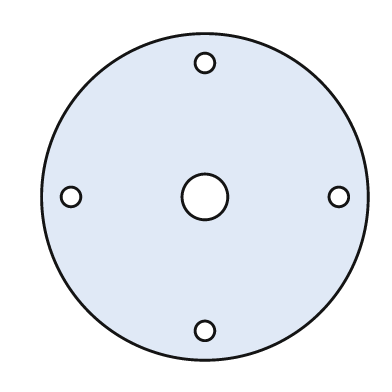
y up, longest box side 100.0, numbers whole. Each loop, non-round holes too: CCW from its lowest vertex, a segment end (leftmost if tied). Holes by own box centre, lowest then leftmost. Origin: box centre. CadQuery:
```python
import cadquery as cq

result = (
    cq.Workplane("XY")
    .moveTo(0.0, 0.0)
    .circle(50.0)
    .moveTo(0.0, -41.0)
    .circle(3.0)
    .moveTo(-41.0, 0.0)
    .circle(3.0)
    .moveTo(0.0, 0.0)
    .circle(7.0)
    .moveTo(41.0, 0.0)
    .circle(3.0)
    .moveTo(0.0, 41.0)
    .circle(3.0)
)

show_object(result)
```